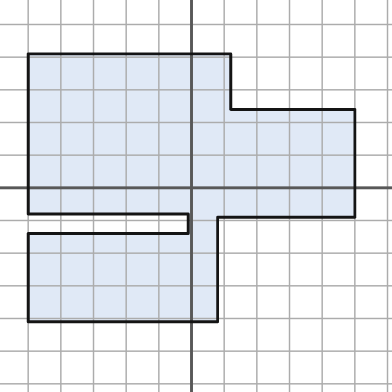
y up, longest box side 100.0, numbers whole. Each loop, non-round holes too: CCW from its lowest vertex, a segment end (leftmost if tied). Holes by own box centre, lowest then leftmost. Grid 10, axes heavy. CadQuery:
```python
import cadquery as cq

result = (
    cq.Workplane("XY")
    .moveTo(-50.0, -41.0)
    .lineTo(8.0, -41.0)
    .lineTo(8.0, -9.0)
    .lineTo(50.0, -9.0)
    .lineTo(50.0, 24.0)
    .lineTo(12.0, 24.0)
    .lineTo(12.0, 41.0)
    .lineTo(-50.0, 41.0)
    .lineTo(-50.0, -8.0)
    .lineTo(-1.0, -8.0)
    .lineTo(-1.0, -14.0)
    .lineTo(-50.0, -14.0)
    .close()
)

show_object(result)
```